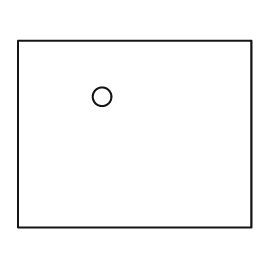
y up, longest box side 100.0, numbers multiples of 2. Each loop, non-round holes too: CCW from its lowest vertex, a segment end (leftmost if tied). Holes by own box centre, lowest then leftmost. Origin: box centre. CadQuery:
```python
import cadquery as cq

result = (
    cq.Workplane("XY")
    .moveTo(-50.0, -40.0)
    .lineTo(50.0, -40.0)
    .lineTo(50.0, 40.0)
    .lineTo(-50.0, 40.0)
    .close()
    .moveTo(-14.0, 16.0)
    .circle(4.0)
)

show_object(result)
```